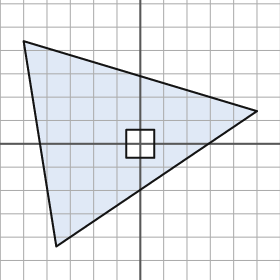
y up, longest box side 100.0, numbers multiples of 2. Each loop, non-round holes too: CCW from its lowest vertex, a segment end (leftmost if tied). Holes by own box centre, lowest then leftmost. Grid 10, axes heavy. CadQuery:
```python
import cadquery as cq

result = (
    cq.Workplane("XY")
    .moveTo(-36.0, -44.0)
    .lineTo(50.0, 14.0)
    .lineTo(-50.0, 44.0)
    .close()
    .moveTo(-6.0, -6.0)
    .lineTo(6.0, -6.0)
    .lineTo(6.0, 6.0)
    .lineTo(-6.0, 6.0)
    .close()
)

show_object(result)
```